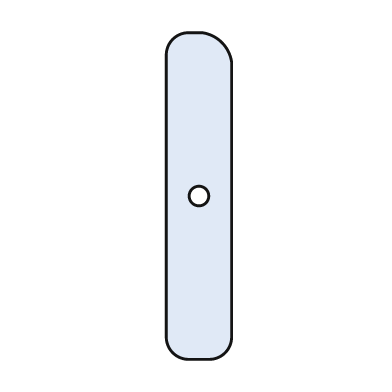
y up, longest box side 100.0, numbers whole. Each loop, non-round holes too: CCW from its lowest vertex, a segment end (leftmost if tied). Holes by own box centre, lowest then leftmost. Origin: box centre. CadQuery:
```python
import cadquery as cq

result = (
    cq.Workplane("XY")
    .moveTo(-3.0, -50.0)
    .lineTo(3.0, -50.0)
    .threePointArc((8.0, -48.0), (10.0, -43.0))
    .lineTo(10.0, 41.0)
    .threePointArc((7.0, 47.0), (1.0, 50.0))
    .lineTo(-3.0, 50.0)
    .threePointArc((-8.0, 48.0), (-10.0, 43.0))
    .lineTo(-10.0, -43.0)
    .threePointArc((-8.0, -48.0), (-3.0, -50.0))
    .close()
    .moveTo(0.0, 0.0)
    .circle(3.0)
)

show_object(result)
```